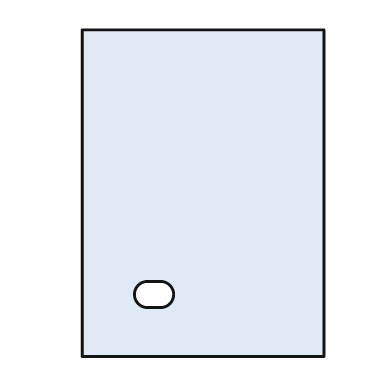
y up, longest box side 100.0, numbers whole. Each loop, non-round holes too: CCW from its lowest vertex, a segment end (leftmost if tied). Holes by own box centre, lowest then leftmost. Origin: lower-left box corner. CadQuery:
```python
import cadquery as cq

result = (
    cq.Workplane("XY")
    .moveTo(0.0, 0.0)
    .lineTo(74.0, 0.0)
    .lineTo(74.0, 100.0)
    .lineTo(0.0, 100.0)
    .close()
    .moveTo(20.0, 15.0)
    .lineTo(24.0, 15.0)
    .threePointArc((28.0, 19.0), (24.0, 23.0))
    .lineTo(20.0, 23.0)
    .threePointArc((16.0, 19.0), (20.0, 15.0))
    .close()
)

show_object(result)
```